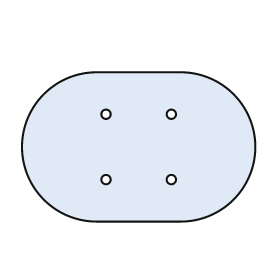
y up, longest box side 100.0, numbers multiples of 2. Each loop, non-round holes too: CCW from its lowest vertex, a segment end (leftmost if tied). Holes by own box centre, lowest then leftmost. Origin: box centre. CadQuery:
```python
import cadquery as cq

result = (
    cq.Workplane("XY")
    .moveTo(-18.0, -32.0)
    .lineTo(18.0, -32.0)
    .threePointArc((50.0, 0.0), (18.0, 32.0))
    .lineTo(-18.0, 32.0)
    .threePointArc((-50.0, 0.0), (-18.0, -32.0))
    .close()
    .moveTo(-14.0, -14.0)
    .circle(2.0)
    .moveTo(14.0, -14.0)
    .circle(2.0)
    .moveTo(-14.0, 14.0)
    .circle(2.0)
    .moveTo(14.0, 14.0)
    .circle(2.0)
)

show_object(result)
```